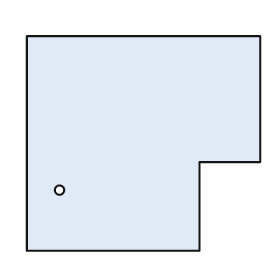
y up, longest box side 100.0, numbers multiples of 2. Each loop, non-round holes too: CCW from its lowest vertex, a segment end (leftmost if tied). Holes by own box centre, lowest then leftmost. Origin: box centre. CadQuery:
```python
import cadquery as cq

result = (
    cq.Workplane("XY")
    .moveTo(-50.0, -46.0)
    .lineTo(24.0, -46.0)
    .lineTo(24.0, -8.0)
    .lineTo(50.0, -8.0)
    .lineTo(50.0, 46.0)
    .lineTo(-50.0, 46.0)
    .close()
    .moveTo(-36.0, -20.0)
    .circle(2.0)
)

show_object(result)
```